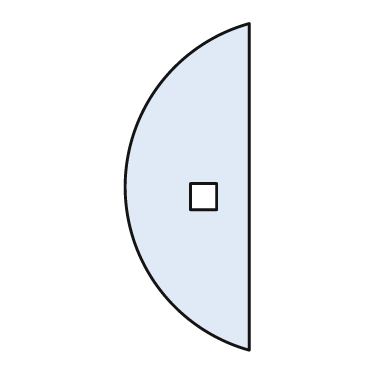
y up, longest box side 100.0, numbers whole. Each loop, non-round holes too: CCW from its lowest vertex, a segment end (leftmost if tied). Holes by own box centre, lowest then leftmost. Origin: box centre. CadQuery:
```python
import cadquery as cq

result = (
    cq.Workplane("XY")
    .moveTo(19.0, -50.0)
    .lineTo(19.0, 50.0)
    .threePointArc((-19.0, 0.0), (19.0, -50.0))
    .close()
    .moveTo(1.0, -7.0)
    .lineTo(9.0, -7.0)
    .lineTo(9.0, 1.0)
    .lineTo(1.0, 1.0)
    .close()
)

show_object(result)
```